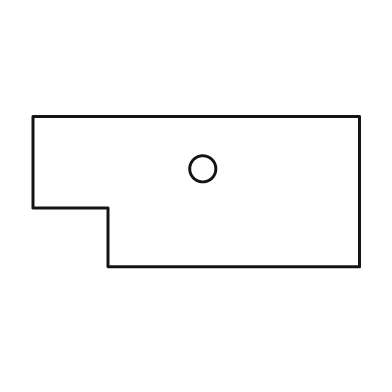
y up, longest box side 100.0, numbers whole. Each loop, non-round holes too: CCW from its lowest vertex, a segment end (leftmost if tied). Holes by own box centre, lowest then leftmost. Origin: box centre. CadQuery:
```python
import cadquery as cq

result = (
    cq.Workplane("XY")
    .moveTo(-27.0, -23.0)
    .lineTo(50.0, -23.0)
    .lineTo(50.0, 23.0)
    .lineTo(-50.0, 23.0)
    .lineTo(-50.0, -5.0)
    .lineTo(-27.0, -5.0)
    .close()
    .moveTo(2.0, 7.0)
    .circle(4.0)
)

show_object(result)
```